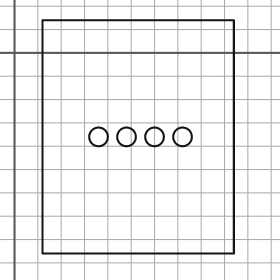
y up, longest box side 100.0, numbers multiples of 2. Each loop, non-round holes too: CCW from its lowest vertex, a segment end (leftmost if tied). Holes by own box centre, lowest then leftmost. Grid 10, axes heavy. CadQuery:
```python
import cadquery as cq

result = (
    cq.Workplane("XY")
    .moveTo(12.0, -86.0)
    .lineTo(94.0, -86.0)
    .lineTo(94.0, 14.0)
    .lineTo(12.0, 14.0)
    .close()
    .moveTo(36.0, -36.0)
    .circle(4.0)
    .moveTo(48.0, -36.0)
    .circle(4.0)
    .moveTo(60.0, -36.0)
    .circle(4.0)
    .moveTo(72.0, -36.0)
    .circle(4.0)
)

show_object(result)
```